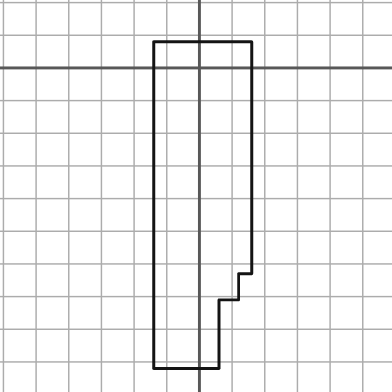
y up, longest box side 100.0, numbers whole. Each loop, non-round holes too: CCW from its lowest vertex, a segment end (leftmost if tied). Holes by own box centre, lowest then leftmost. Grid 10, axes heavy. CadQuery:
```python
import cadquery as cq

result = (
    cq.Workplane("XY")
    .moveTo(-14.0, -92.0)
    .lineTo(6.0, -92.0)
    .lineTo(6.0, -71.0)
    .lineTo(12.0, -71.0)
    .lineTo(12.0, -63.0)
    .lineTo(16.0, -63.0)
    .lineTo(16.0, 8.0)
    .lineTo(-14.0, 8.0)
    .close()
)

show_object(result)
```